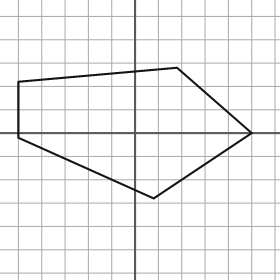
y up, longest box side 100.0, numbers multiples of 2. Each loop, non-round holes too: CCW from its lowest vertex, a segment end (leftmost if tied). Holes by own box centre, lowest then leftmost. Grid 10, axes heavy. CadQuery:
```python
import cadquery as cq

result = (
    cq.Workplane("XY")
    .moveTo(8.0, -28.0)
    .lineTo(50.0, 0.0)
    .lineTo(18.0, 28.0)
    .lineTo(-50.0, 22.0)
    .lineTo(-50.0, -2.0)
    .close()
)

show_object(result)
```